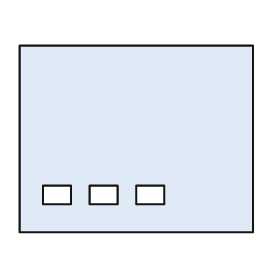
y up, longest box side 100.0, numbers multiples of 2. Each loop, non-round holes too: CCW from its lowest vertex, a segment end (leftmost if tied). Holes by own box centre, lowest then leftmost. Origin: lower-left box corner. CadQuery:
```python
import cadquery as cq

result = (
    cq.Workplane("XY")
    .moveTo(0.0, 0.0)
    .lineTo(100.0, 0.0)
    .lineTo(100.0, 80.0)
    .lineTo(0.0, 80.0)
    .close()
    .moveTo(10.0, 12.0)
    .lineTo(22.0, 12.0)
    .lineTo(22.0, 20.0)
    .lineTo(10.0, 20.0)
    .close()
    .moveTo(30.0, 12.0)
    .lineTo(42.0, 12.0)
    .lineTo(42.0, 20.0)
    .lineTo(30.0, 20.0)
    .close()
    .moveTo(50.0, 12.0)
    .lineTo(62.0, 12.0)
    .lineTo(62.0, 20.0)
    .lineTo(50.0, 20.0)
    .close()
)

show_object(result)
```